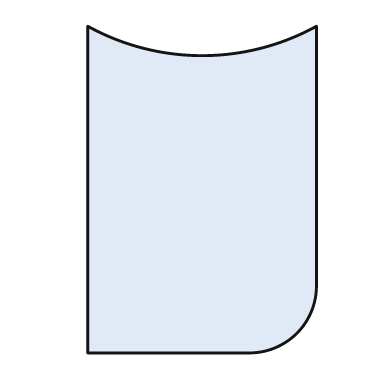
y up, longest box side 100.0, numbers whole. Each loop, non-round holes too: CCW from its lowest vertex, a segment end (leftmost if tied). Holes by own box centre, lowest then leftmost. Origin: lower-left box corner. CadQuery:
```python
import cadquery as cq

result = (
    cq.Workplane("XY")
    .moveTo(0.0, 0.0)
    .lineTo(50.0, 0.0)
    .threePointArc((64.0, 6.0), (70.0, 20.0))
    .lineTo(70.0, 100.0)
    .threePointArc((35.0, 91.0), (0.0, 100.0))
    .close()
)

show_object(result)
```